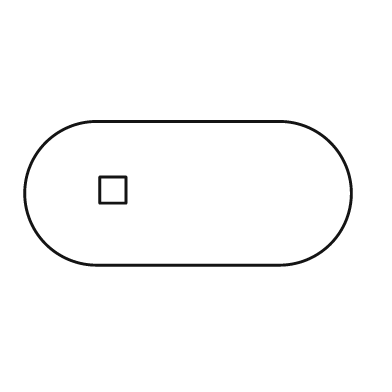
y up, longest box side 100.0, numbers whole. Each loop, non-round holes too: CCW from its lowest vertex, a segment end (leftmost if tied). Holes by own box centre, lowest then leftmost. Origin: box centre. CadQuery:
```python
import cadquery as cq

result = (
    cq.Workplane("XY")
    .moveTo(-28.0, -22.0)
    .lineTo(28.0, -22.0)
    .threePointArc((50.0, 0.0), (28.0, 22.0))
    .lineTo(-28.0, 22.0)
    .threePointArc((-50.0, 0.0), (-28.0, -22.0))
    .close()
    .moveTo(-27.0, -3.0)
    .lineTo(-19.0, -3.0)
    .lineTo(-19.0, 5.0)
    .lineTo(-27.0, 5.0)
    .close()
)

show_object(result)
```